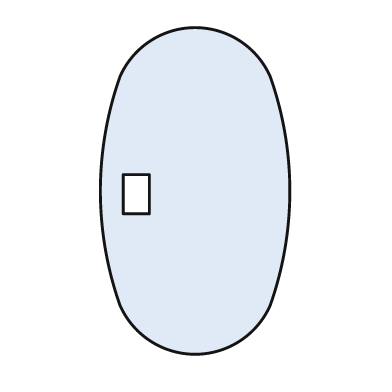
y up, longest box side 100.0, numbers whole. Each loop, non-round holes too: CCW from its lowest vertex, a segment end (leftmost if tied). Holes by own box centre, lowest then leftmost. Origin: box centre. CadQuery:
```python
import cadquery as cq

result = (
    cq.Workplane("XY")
    .moveTo(-23.0, -35.0)
    .threePointArc((0.0, -50.0), (23.0, -35.0))
    .threePointArc((29.0, 0.0), (23.0, 35.0))
    .threePointArc((0.0, 50.0), (-23.0, 35.0))
    .threePointArc((-29.0, 0.0), (-23.0, -35.0))
    .close()
    .moveTo(-22.0, -7.0)
    .lineTo(-14.0, -7.0)
    .lineTo(-14.0, 5.0)
    .lineTo(-22.0, 5.0)
    .close()
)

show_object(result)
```